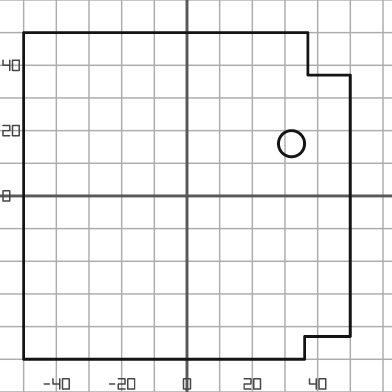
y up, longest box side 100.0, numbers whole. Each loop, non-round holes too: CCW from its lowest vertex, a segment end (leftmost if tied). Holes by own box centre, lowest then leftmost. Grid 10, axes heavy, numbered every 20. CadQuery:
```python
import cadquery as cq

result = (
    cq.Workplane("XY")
    .moveTo(-50.0, -50.0)
    .lineTo(36.0, -50.0)
    .lineTo(36.0, -43.0)
    .lineTo(50.0, -43.0)
    .lineTo(50.0, 37.0)
    .lineTo(37.0, 37.0)
    .lineTo(37.0, 50.0)
    .lineTo(-50.0, 50.0)
    .close()
    .moveTo(32.0, 16.0)
    .circle(4.0)
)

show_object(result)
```